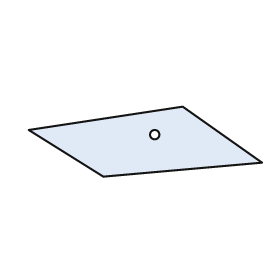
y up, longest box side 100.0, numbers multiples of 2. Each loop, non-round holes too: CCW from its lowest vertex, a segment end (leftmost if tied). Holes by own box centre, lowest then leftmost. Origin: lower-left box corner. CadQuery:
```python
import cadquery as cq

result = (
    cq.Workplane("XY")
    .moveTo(32.0, 0.0)
    .lineTo(100.0, 6.0)
    .lineTo(66.0, 30.0)
    .lineTo(0.0, 20.0)
    .close()
    .moveTo(54.0, 18.0)
    .circle(2.0)
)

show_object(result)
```